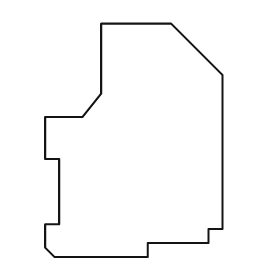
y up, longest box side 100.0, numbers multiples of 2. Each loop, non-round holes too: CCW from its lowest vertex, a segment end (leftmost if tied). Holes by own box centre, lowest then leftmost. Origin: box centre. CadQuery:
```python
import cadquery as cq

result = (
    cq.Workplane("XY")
    .moveTo(-34.0, -50.0)
    .lineTo(6.0, -50.0)
    .lineTo(6.0, -44.0)
    .lineTo(32.0, -44.0)
    .lineTo(32.0, -38.0)
    .lineTo(38.0, -38.0)
    .lineTo(38.0, 28.0)
    .lineTo(16.0, 50.0)
    .lineTo(-14.0, 50.0)
    .lineTo(-14.0, 20.0)
    .lineTo(-22.0, 10.0)
    .lineTo(-38.0, 10.0)
    .lineTo(-38.0, -8.0)
    .lineTo(-32.0, -8.0)
    .lineTo(-32.0, -36.0)
    .lineTo(-38.0, -36.0)
    .lineTo(-38.0, -46.0)
    .close()
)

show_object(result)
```